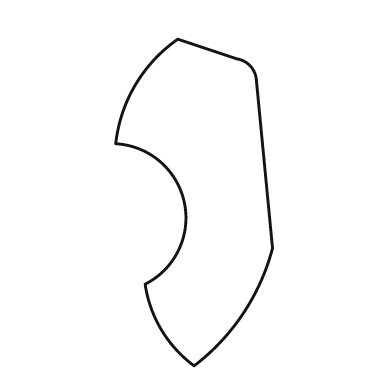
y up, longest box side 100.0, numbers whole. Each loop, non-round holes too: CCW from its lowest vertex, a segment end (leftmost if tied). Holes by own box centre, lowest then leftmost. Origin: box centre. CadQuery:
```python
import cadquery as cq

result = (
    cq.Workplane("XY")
    .moveTo(0.0, -50.0)
    .threePointArc((15.0, -34.0), (24.0, -14.0))
    .lineTo(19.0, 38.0)
    .threePointArc((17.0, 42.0), (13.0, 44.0))
    .lineTo(-5.0, 50.0)
    .threePointArc((-18.0, 36.0), (-24.0, 18.0))
    .threePointArc((-3.0, 0.0), (-15.0, -25.0))
    .threePointArc((-10.0, -39.0), (0.0, -50.0))
    .close()
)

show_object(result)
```